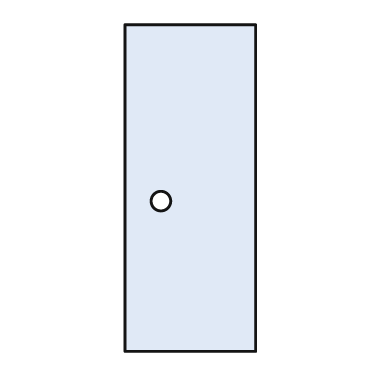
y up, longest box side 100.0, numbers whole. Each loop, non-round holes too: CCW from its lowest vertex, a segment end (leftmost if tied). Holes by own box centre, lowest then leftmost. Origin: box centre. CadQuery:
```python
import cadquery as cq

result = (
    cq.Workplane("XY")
    .moveTo(-20.0, -50.0)
    .lineTo(20.0, -50.0)
    .lineTo(20.0, 50.0)
    .lineTo(-20.0, 50.0)
    .close()
    .moveTo(-9.0, -4.0)
    .circle(3.0)
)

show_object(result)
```